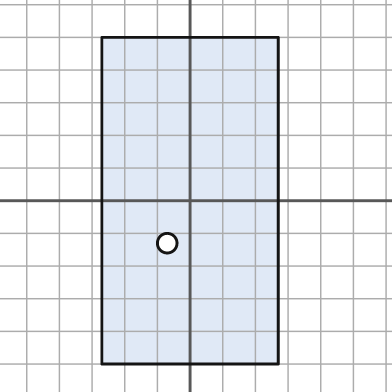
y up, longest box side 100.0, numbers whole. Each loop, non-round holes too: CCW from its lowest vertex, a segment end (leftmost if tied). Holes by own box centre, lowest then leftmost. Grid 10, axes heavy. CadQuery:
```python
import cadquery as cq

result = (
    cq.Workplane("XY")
    .moveTo(-27.0, -50.0)
    .lineTo(27.0, -50.0)
    .lineTo(27.0, 50.0)
    .lineTo(-27.0, 50.0)
    .close()
    .moveTo(-7.0, -13.0)
    .circle(3.0)
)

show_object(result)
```